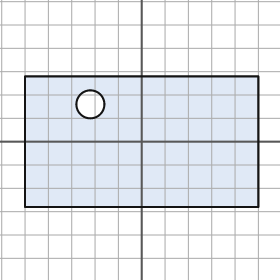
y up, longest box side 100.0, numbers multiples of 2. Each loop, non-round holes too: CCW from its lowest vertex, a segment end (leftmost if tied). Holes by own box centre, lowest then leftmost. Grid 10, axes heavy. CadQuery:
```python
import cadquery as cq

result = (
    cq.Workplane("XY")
    .moveTo(-50.0, -28.0)
    .lineTo(50.0, -28.0)
    .lineTo(50.0, 28.0)
    .lineTo(-50.0, 28.0)
    .close()
    .moveTo(-22.0, 16.0)
    .circle(6.0)
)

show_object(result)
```